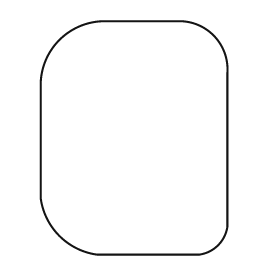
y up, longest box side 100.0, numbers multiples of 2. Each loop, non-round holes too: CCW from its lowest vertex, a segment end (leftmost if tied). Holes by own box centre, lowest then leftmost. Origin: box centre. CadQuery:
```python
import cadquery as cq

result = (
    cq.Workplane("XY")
    .moveTo(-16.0, -50.0)
    .lineTo(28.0, -50.0)
    .threePointArc((36.0, -46.0), (40.0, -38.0))
    .lineTo(40.0, 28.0)
    .threePointArc((34.0, 44.0), (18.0, 50.0))
    .lineTo(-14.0, 50.0)
    .threePointArc((-32.0, 42.0), (-40.0, 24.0))
    .lineTo(-40.0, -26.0)
    .threePointArc((-32.0, -42.0), (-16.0, -50.0))
    .close()
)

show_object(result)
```